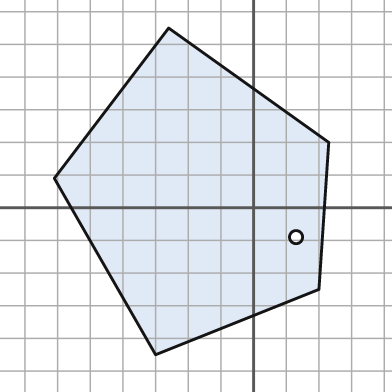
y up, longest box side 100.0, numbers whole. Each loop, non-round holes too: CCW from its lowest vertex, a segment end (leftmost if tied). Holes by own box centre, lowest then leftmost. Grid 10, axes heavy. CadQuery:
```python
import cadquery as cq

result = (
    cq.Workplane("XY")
    .moveTo(-30.0, -45.0)
    .lineTo(20.0, -25.0)
    .lineTo(23.0, 20.0)
    .lineTo(-26.0, 55.0)
    .lineTo(-61.0, 9.0)
    .close()
    .moveTo(13.0, -9.0)
    .circle(2.0)
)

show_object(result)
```